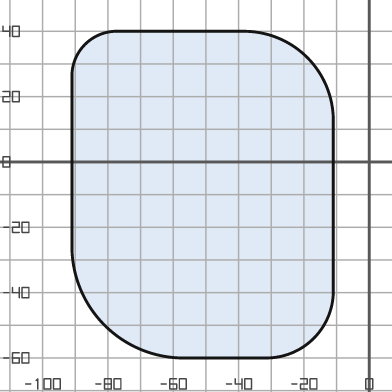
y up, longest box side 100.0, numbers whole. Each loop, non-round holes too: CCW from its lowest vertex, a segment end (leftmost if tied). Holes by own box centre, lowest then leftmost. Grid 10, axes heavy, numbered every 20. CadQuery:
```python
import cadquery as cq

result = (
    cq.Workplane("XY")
    .moveTo(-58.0, -60.0)
    .lineTo(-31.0, -60.0)
    .threePointArc((-17.0, -54.0), (-11.0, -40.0))
    .lineTo(-11.0, 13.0)
    .threePointArc((-19.0, 32.0), (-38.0, 40.0))
    .lineTo(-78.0, 40.0)
    .threePointArc((-87.0, 36.0), (-91.0, 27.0))
    .lineTo(-91.0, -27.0)
    .threePointArc((-81.0, -50.0), (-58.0, -60.0))
    .close()
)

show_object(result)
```